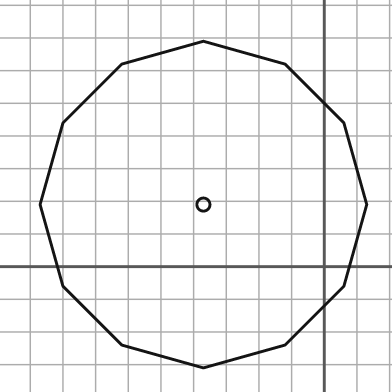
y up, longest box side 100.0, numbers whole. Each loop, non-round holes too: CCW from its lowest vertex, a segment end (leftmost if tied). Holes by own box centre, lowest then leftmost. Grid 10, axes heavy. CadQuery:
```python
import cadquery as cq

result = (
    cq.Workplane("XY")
    .moveTo(-37.0, -31.0)
    .lineTo(-12.0, -24.0)
    .lineTo(6.0, -6.0)
    .lineTo(13.0, 19.0)
    .lineTo(6.0, 44.0)
    .lineTo(-12.0, 62.0)
    .lineTo(-37.0, 69.0)
    .lineTo(-62.0, 62.0)
    .lineTo(-80.0, 44.0)
    .lineTo(-87.0, 19.0)
    .lineTo(-80.0, -6.0)
    .lineTo(-62.0, -24.0)
    .close()
    .moveTo(-37.0, 19.0)
    .circle(2.0)
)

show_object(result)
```